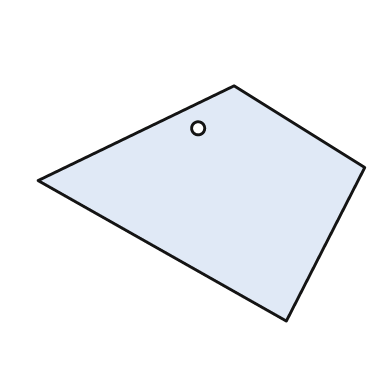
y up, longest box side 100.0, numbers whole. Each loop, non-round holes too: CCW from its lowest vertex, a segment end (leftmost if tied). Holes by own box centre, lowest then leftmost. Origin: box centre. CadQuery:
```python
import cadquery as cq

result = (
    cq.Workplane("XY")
    .moveTo(26.0, -36.0)
    .lineTo(50.0, 11.0)
    .lineTo(10.0, 36.0)
    .lineTo(-50.0, 7.0)
    .close()
    .moveTo(-1.0, 23.0)
    .circle(2.0)
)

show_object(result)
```